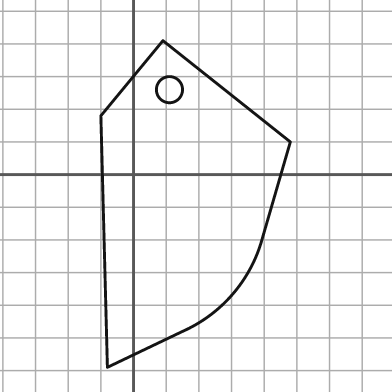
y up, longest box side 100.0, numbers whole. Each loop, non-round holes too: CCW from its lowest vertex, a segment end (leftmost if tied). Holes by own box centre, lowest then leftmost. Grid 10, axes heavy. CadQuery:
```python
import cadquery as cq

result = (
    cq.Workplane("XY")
    .moveTo(-8.0, -59.0)
    .lineTo(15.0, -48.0)
    .threePointArc((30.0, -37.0), (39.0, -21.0))
    .lineTo(48.0, 10.0)
    .lineTo(9.0, 41.0)
    .lineTo(-10.0, 18.0)
    .close()
    .moveTo(11.0, 26.0)
    .circle(4.0)
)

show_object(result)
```